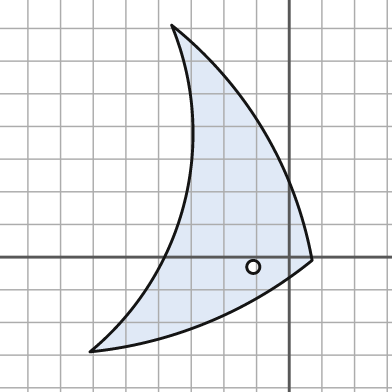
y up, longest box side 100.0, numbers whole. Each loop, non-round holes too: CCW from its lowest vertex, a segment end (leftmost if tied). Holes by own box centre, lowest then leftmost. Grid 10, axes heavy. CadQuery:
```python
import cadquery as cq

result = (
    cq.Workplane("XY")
    .moveTo(-61.0, -29.0)
    .threePointArc((-25.0, -20.0), (7.0, -1.0))
    .threePointArc((-8.0, 39.0), (-36.0, 71.0))
    .threePointArc((-32.0, 17.0), (-61.0, -29.0))
    .close()
    .moveTo(-11.0, -3.0)
    .circle(2.0)
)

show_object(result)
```